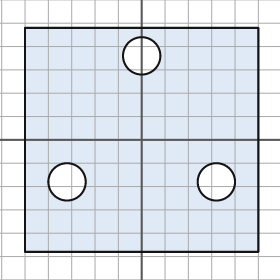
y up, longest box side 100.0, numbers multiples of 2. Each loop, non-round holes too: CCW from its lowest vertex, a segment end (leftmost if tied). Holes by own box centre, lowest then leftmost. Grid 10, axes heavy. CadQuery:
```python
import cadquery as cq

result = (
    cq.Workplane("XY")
    .moveTo(-50.0, -48.0)
    .lineTo(50.0, -48.0)
    .lineTo(50.0, 48.0)
    .lineTo(-50.0, 48.0)
    .close()
    .moveTo(-32.0, -18.0)
    .circle(8.0)
    .moveTo(32.0, -18.0)
    .circle(8.0)
    .moveTo(0.0, 36.0)
    .circle(8.0)
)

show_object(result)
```